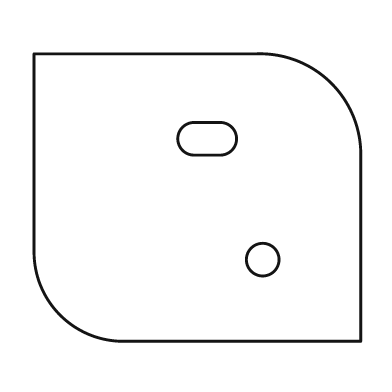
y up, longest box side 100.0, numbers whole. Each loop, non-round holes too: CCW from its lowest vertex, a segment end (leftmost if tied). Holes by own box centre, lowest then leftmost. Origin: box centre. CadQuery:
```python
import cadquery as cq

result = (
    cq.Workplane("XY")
    .moveTo(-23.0, -44.0)
    .lineTo(50.0, -44.0)
    .lineTo(50.0, 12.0)
    .threePointArc((41.0, 35.0), (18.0, 44.0))
    .lineTo(-50.0, 44.0)
    .lineTo(-50.0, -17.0)
    .threePointArc((-42.0, -36.0), (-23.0, -44.0))
    .close()
    .moveTo(20.0, -19.0)
    .circle(5.0)
    .moveTo(-1.0, 13.0)
    .lineTo(7.0, 13.0)
    .threePointArc((12.0, 18.0), (7.0, 23.0))
    .lineTo(-1.0, 23.0)
    .threePointArc((-6.0, 18.0), (-1.0, 13.0))
    .close()
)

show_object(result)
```